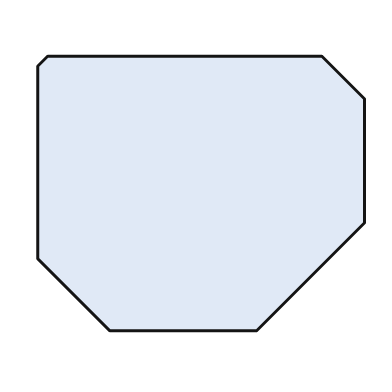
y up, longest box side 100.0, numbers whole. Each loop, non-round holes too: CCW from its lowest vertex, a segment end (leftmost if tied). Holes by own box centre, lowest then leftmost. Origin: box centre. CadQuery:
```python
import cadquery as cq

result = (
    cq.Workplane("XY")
    .moveTo(-28.0, -42.0)
    .lineTo(17.0, -42.0)
    .lineTo(50.0, -9.0)
    .lineTo(50.0, 29.0)
    .lineTo(37.0, 42.0)
    .lineTo(-47.0, 42.0)
    .lineTo(-50.0, 39.0)
    .lineTo(-50.0, -20.0)
    .close()
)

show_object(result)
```